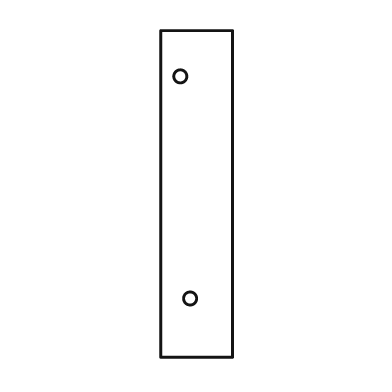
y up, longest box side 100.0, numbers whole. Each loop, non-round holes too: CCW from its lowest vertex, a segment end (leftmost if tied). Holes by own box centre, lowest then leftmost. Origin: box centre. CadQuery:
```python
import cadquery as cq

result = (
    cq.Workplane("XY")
    .moveTo(-11.0, -50.0)
    .lineTo(11.0, -50.0)
    .lineTo(11.0, 50.0)
    .lineTo(-11.0, 50.0)
    .close()
    .moveTo(-2.0, -32.0)
    .circle(2.0)
    .moveTo(-5.0, 36.0)
    .circle(2.0)
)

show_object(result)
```